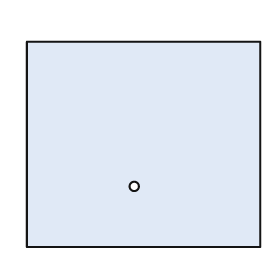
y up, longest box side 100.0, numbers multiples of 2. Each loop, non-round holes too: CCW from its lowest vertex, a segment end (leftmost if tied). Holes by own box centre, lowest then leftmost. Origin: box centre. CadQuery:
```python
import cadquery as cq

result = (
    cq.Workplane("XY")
    .moveTo(-50.0, -44.0)
    .lineTo(50.0, -44.0)
    .lineTo(50.0, 44.0)
    .lineTo(-50.0, 44.0)
    .close()
    .moveTo(-4.0, -18.0)
    .circle(2.0)
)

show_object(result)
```